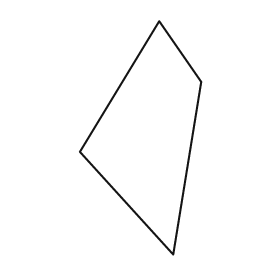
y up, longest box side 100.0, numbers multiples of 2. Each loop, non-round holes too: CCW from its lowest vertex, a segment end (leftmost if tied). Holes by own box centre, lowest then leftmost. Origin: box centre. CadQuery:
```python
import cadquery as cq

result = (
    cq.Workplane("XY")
    .moveTo(14.0, -50.0)
    .lineTo(26.0, 24.0)
    .lineTo(8.0, 50.0)
    .lineTo(-26.0, -6.0)
    .close()
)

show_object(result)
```